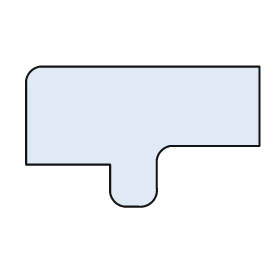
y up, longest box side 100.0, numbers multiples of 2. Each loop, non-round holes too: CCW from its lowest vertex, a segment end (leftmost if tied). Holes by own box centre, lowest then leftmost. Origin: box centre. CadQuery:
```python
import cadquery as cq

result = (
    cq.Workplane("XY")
    .moveTo(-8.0, -30.0)
    .lineTo(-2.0, -30.0)
    .threePointArc((4.0, -28.0), (6.0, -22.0))
    .lineTo(6.0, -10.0)
    .threePointArc((8.0, -6.0), (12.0, -4.0))
    .lineTo(50.0, -4.0)
    .lineTo(50.0, 30.0)
    .lineTo(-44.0, 30.0)
    .threePointArc((-48.0, 28.0), (-50.0, 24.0))
    .lineTo(-50.0, -12.0)
    .lineTo(-14.0, -12.0)
    .lineTo(-14.0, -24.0)
    .threePointArc((-12.0, -28.0), (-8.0, -30.0))
    .close()
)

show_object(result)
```